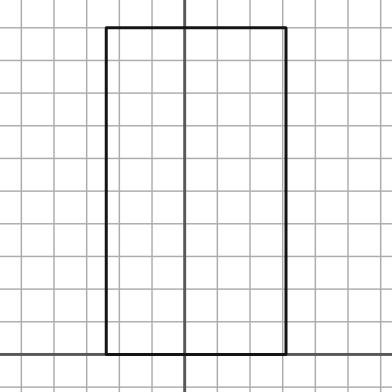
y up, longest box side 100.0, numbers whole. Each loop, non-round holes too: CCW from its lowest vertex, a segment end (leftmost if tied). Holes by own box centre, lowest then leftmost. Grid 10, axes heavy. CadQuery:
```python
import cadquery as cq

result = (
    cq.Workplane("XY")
    .moveTo(-24.0, 0.0)
    .lineTo(31.0, 0.0)
    .lineTo(31.0, 100.0)
    .lineTo(-24.0, 100.0)
    .close()
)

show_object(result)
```